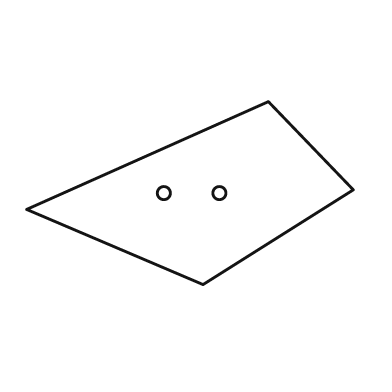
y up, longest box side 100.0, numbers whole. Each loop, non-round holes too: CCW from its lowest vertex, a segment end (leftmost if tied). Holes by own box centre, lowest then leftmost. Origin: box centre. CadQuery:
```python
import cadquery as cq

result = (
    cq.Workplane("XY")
    .moveTo(4.0, -28.0)
    .lineTo(50.0, 1.0)
    .lineTo(24.0, 28.0)
    .lineTo(-50.0, -5.0)
    .close()
    .moveTo(-8.0, 0.0)
    .circle(2.0)
    .moveTo(9.0, 0.0)
    .circle(2.0)
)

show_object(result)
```